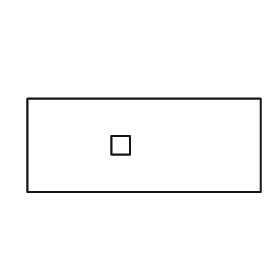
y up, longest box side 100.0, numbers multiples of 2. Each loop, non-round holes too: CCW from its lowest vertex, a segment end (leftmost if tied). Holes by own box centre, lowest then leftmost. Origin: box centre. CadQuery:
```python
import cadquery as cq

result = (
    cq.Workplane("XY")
    .moveTo(-50.0, -20.0)
    .lineTo(50.0, -20.0)
    .lineTo(50.0, 20.0)
    .lineTo(-50.0, 20.0)
    .close()
    .moveTo(-14.0, -4.0)
    .lineTo(-6.0, -4.0)
    .lineTo(-6.0, 4.0)
    .lineTo(-14.0, 4.0)
    .close()
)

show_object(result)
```